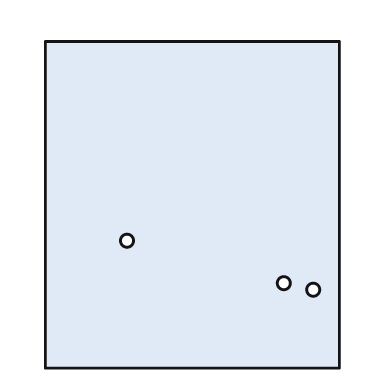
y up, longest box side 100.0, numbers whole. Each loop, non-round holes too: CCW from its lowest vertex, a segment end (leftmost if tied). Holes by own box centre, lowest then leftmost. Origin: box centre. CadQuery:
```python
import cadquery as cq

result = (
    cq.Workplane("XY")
    .moveTo(-45.0, -50.0)
    .lineTo(45.0, -50.0)
    .lineTo(45.0, 50.0)
    .lineTo(-45.0, 50.0)
    .close()
    .moveTo(37.0, -26.0)
    .circle(2.0)
    .moveTo(28.0, -24.0)
    .circle(2.0)
    .moveTo(-20.0, -11.0)
    .circle(2.0)
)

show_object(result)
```